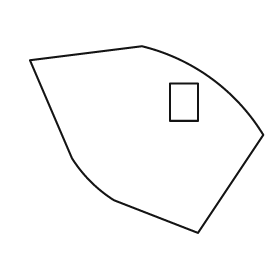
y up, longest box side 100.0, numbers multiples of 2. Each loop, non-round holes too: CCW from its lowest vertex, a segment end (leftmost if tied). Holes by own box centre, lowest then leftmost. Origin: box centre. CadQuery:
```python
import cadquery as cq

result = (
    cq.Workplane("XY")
    .moveTo(22.0, -40.0)
    .lineTo(50.0, 2.0)
    .threePointArc((28.0, 26.0), (-2.0, 40.0))
    .lineTo(-50.0, 34.0)
    .lineTo(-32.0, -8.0)
    .threePointArc((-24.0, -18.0), (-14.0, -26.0))
    .close()
    .moveTo(10.0, 8.0)
    .lineTo(22.0, 8.0)
    .lineTo(22.0, 24.0)
    .lineTo(10.0, 24.0)
    .close()
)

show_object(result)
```